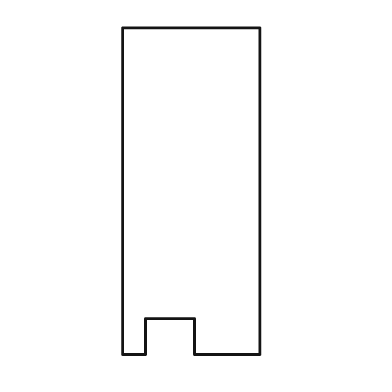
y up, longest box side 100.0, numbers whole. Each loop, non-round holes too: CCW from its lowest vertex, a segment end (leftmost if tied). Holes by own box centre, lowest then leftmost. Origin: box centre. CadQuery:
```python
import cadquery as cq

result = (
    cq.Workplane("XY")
    .moveTo(-21.0, -50.0)
    .lineTo(-14.0, -50.0)
    .lineTo(-14.0, -39.0)
    .lineTo(1.0, -39.0)
    .lineTo(1.0, -50.0)
    .lineTo(21.0, -50.0)
    .lineTo(21.0, 50.0)
    .lineTo(-21.0, 50.0)
    .close()
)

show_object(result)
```